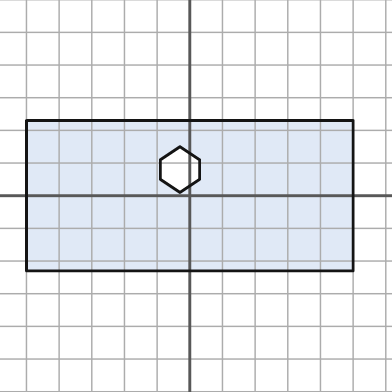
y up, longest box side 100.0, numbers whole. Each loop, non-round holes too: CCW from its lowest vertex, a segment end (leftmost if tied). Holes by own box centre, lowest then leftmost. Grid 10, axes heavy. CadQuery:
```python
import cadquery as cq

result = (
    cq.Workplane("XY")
    .moveTo(-50.0, -23.0)
    .lineTo(50.0, -23.0)
    .lineTo(50.0, 23.0)
    .lineTo(-50.0, 23.0)
    .close()
    .moveTo(-3.0, 1.0)
    .lineTo(3.0, 5.0)
    .lineTo(3.0, 11.0)
    .lineTo(-3.0, 15.0)
    .lineTo(-9.0, 11.0)
    .lineTo(-9.0, 5.0)
    .close()
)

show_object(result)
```